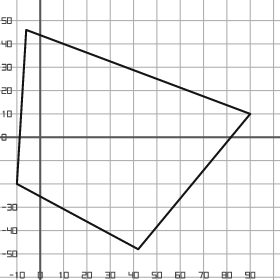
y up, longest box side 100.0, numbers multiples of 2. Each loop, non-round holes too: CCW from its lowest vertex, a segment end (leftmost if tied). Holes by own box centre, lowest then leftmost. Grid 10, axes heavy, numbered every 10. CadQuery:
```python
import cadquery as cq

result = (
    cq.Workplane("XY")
    .moveTo(42.0, -48.0)
    .lineTo(90.0, 10.0)
    .lineTo(-6.0, 46.0)
    .lineTo(-10.0, -20.0)
    .close()
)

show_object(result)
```